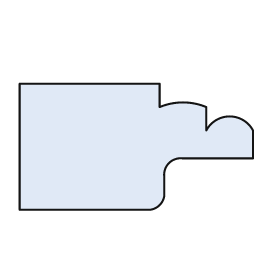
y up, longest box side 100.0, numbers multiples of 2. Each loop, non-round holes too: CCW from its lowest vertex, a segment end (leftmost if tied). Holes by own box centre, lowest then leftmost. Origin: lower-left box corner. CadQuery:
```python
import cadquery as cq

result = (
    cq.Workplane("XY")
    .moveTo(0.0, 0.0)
    .lineTo(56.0, 0.0)
    .threePointArc((60.0, 2.0), (62.0, 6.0))
    .lineTo(62.0, 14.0)
    .threePointArc((64.0, 20.0), (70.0, 22.0))
    .lineTo(100.0, 22.0)
    .lineTo(100.0, 34.0)
    .threePointArc((90.0, 40.0), (80.0, 34.0))
    .lineTo(80.0, 44.0)
    .threePointArc((70.0, 46.0), (60.0, 44.0))
    .lineTo(60.0, 54.0)
    .lineTo(0.0, 54.0)
    .close()
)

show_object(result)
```